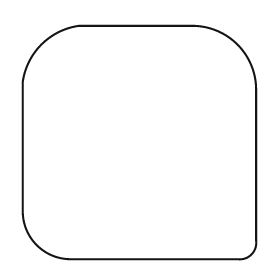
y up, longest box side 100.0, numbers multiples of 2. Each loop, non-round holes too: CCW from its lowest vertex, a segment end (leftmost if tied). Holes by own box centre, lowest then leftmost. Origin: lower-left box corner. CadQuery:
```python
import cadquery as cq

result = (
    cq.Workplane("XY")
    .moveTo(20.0, 0.0)
    .lineTo(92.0, 0.0)
    .threePointArc((98.0, 2.0), (100.0, 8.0))
    .lineTo(100.0, 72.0)
    .threePointArc((92.0, 92.0), (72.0, 100.0))
    .lineTo(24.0, 100.0)
    .threePointArc((8.0, 92.0), (0.0, 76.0))
    .lineTo(0.0, 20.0)
    .threePointArc((6.0, 6.0), (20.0, 0.0))
    .close()
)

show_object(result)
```